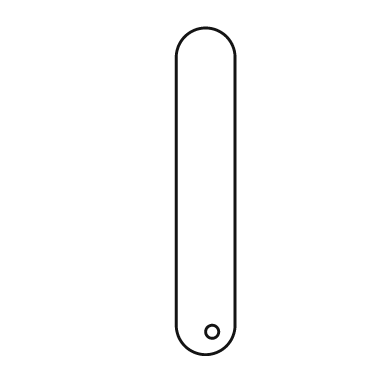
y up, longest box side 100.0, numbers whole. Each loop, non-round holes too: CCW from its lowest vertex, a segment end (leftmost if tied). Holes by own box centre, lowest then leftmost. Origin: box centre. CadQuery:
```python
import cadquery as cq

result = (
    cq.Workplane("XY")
    .moveTo(-9.0, -41.0)
    .threePointArc((0.0, -50.0), (9.0, -41.0))
    .lineTo(9.0, 41.0)
    .threePointArc((0.0, 50.0), (-9.0, 41.0))
    .close()
    .moveTo(2.0, -43.0)
    .circle(2.0)
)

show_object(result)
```